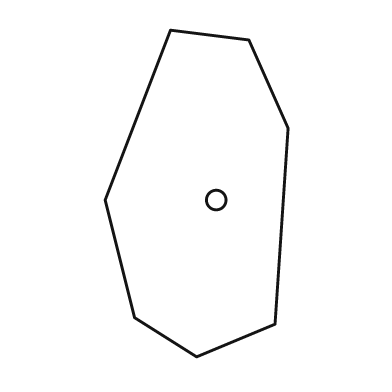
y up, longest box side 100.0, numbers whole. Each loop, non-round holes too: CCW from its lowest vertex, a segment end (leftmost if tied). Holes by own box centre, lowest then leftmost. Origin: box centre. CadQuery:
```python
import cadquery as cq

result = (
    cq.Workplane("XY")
    .moveTo(0.0, -50.0)
    .lineTo(24.0, -40.0)
    .lineTo(28.0, 20.0)
    .lineTo(16.0, 47.0)
    .lineTo(-8.0, 50.0)
    .lineTo(-28.0, -2.0)
    .lineTo(-19.0, -38.0)
    .close()
    .moveTo(6.0, -2.0)
    .circle(3.0)
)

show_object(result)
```